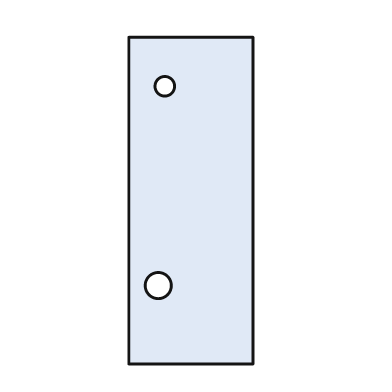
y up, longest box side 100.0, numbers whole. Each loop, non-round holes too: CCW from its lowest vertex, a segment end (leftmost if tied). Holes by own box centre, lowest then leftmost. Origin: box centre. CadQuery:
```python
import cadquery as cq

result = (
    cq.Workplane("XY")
    .moveTo(-19.0, -50.0)
    .lineTo(19.0, -50.0)
    .lineTo(19.0, 50.0)
    .lineTo(-19.0, 50.0)
    .close()
    .moveTo(-10.0, -26.0)
    .circle(4.0)
    .moveTo(-8.0, 35.0)
    .circle(3.0)
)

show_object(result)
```